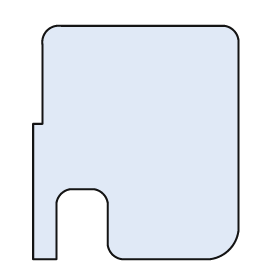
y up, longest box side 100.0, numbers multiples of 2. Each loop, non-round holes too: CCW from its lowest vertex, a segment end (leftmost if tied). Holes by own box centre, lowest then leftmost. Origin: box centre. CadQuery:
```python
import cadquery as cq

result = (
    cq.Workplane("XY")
    .moveTo(-44.0, -50.0)
    .lineTo(-34.0, -50.0)
    .lineTo(-34.0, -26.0)
    .threePointArc((-32.0, -22.0), (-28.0, -20.0))
    .lineTo(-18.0, -20.0)
    .threePointArc((-14.0, -22.0), (-12.0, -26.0))
    .lineTo(-12.0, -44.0)
    .threePointArc((-10.0, -48.0), (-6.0, -50.0))
    .lineTo(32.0, -50.0)
    .threePointArc((40.0, -46.0), (44.0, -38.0))
    .lineTo(44.0, 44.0)
    .threePointArc((42.0, 48.0), (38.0, 50.0))
    .lineTo(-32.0, 50.0)
    .threePointArc((-38.0, 48.0), (-40.0, 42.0))
    .lineTo(-40.0, 8.0)
    .lineTo(-44.0, 8.0)
    .close()
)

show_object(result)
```